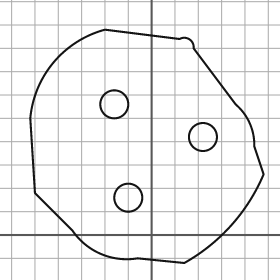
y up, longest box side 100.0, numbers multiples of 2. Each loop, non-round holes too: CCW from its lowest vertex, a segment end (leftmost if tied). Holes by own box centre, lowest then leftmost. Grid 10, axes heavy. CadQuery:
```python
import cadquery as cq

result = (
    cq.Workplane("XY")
    .moveTo(14.0, -12.0)
    .threePointArc((34.0, 4.0), (48.0, 26.0))
    .lineTo(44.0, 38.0)
    .threePointArc((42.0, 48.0), (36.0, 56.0))
    .lineTo(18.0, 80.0)
    .threePointArc((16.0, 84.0), (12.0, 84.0))
    .lineTo(-20.0, 88.0)
    .threePointArc((-42.0, 74.0), (-52.0, 50.0))
    .lineTo(-50.0, 18.0)
    .lineTo(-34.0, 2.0)
    .threePointArc((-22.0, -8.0), (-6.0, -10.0))
    .close()
    .moveTo(-10.0, 16.0)
    .circle(6.0)
    .moveTo(22.0, 42.0)
    .circle(6.0)
    .moveTo(-16.0, 56.0)
    .circle(6.0)
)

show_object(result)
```